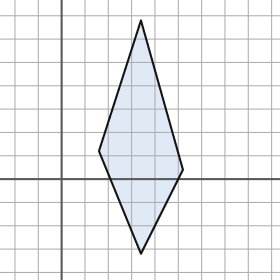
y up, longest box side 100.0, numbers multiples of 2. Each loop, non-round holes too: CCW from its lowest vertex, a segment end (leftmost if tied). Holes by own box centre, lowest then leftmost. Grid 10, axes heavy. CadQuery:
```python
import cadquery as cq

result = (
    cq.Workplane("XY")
    .moveTo(34.0, -32.0)
    .lineTo(52.0, 4.0)
    .lineTo(34.0, 68.0)
    .lineTo(16.0, 12.0)
    .close()
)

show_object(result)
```